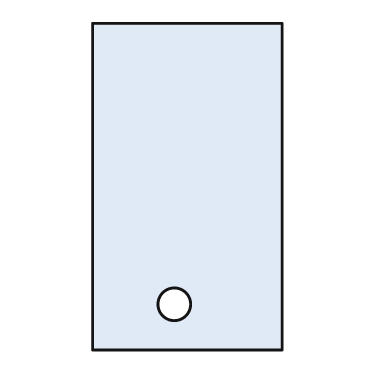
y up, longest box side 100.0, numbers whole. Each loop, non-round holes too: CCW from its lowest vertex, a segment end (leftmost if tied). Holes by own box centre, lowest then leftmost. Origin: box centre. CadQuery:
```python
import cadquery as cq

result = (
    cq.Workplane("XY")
    .moveTo(-29.0, -50.0)
    .lineTo(29.0, -50.0)
    .lineTo(29.0, 50.0)
    .lineTo(-29.0, 50.0)
    .close()
    .moveTo(-4.0, -36.0)
    .circle(5.0)
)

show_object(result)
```